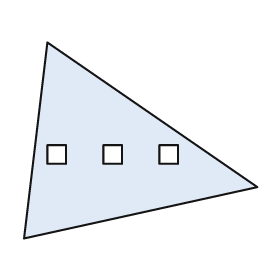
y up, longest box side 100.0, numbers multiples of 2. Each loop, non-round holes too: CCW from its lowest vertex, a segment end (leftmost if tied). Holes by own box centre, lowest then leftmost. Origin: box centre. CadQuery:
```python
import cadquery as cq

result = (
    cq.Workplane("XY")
    .moveTo(-50.0, -42.0)
    .lineTo(50.0, -20.0)
    .lineTo(-40.0, 42.0)
    .close()
    .moveTo(-40.0, -10.0)
    .lineTo(-32.0, -10.0)
    .lineTo(-32.0, -2.0)
    .lineTo(-40.0, -2.0)
    .close()
    .moveTo(-16.0, -10.0)
    .lineTo(-8.0, -10.0)
    .lineTo(-8.0, -2.0)
    .lineTo(-16.0, -2.0)
    .close()
    .moveTo(8.0, -10.0)
    .lineTo(16.0, -10.0)
    .lineTo(16.0, -2.0)
    .lineTo(8.0, -2.0)
    .close()
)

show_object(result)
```